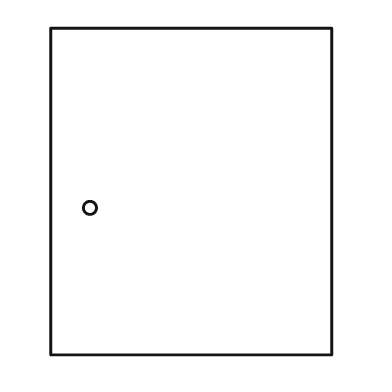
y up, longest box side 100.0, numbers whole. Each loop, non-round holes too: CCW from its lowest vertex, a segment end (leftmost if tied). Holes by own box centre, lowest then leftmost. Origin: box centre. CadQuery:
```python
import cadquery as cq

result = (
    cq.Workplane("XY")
    .moveTo(-43.0, -50.0)
    .lineTo(43.0, -50.0)
    .lineTo(43.0, 50.0)
    .lineTo(-43.0, 50.0)
    .close()
    .moveTo(-31.0, -5.0)
    .circle(2.0)
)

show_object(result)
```